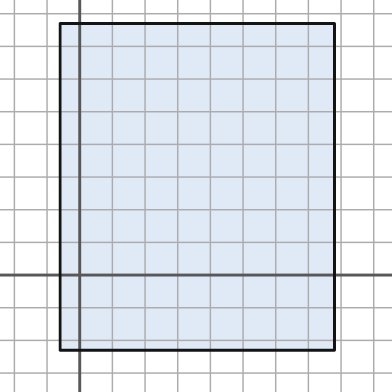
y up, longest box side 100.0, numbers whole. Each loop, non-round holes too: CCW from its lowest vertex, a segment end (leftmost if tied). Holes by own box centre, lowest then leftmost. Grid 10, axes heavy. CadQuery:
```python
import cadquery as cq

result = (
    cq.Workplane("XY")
    .moveTo(-6.0, -23.0)
    .lineTo(78.0, -23.0)
    .lineTo(78.0, 77.0)
    .lineTo(-6.0, 77.0)
    .close()
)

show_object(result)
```